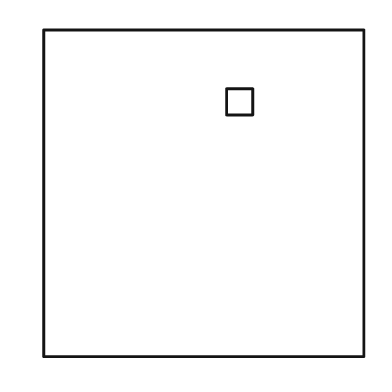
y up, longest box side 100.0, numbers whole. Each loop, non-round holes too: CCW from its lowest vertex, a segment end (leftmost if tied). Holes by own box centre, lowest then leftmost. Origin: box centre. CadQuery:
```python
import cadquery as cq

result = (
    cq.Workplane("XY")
    .moveTo(-49.0, -50.0)
    .lineTo(49.0, -50.0)
    .lineTo(49.0, 50.0)
    .lineTo(-49.0, 50.0)
    .close()
    .moveTo(7.0, 24.0)
    .lineTo(15.0, 24.0)
    .lineTo(15.0, 32.0)
    .lineTo(7.0, 32.0)
    .close()
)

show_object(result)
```